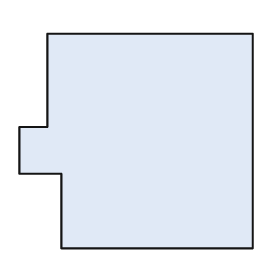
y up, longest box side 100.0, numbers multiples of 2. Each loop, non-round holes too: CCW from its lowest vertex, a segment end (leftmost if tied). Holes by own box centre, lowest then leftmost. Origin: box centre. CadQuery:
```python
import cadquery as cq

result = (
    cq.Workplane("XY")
    .moveTo(-32.0, -46.0)
    .lineTo(50.0, -46.0)
    .lineTo(50.0, 46.0)
    .lineTo(-38.0, 46.0)
    .lineTo(-38.0, 6.0)
    .lineTo(-50.0, 6.0)
    .lineTo(-50.0, -14.0)
    .lineTo(-32.0, -14.0)
    .close()
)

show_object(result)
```